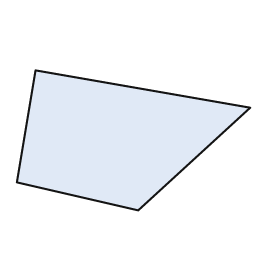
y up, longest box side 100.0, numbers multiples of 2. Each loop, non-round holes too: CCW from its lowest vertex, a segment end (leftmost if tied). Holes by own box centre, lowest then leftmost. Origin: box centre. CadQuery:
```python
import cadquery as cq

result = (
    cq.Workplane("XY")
    .moveTo(2.0, -30.0)
    .lineTo(50.0, 14.0)
    .lineTo(-42.0, 30.0)
    .lineTo(-50.0, -18.0)
    .close()
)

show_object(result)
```